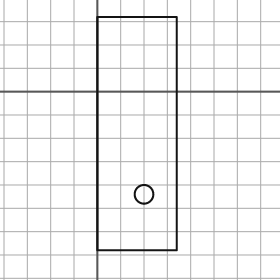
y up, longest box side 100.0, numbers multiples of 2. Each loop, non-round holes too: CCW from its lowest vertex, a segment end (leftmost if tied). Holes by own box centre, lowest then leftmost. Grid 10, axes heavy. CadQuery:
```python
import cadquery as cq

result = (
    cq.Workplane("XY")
    .moveTo(0.0, -68.0)
    .lineTo(34.0, -68.0)
    .lineTo(34.0, 32.0)
    .lineTo(0.0, 32.0)
    .close()
    .moveTo(20.0, -44.0)
    .circle(4.0)
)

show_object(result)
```